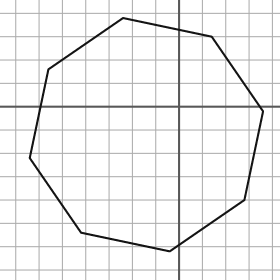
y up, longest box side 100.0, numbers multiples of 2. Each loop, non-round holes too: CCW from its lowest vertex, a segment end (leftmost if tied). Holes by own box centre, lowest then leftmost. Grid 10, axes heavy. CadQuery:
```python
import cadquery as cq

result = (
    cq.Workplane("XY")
    .moveTo(-4.0, -62.0)
    .lineTo(28.0, -40.0)
    .lineTo(36.0, -2.0)
    .lineTo(14.0, 30.0)
    .lineTo(-24.0, 38.0)
    .lineTo(-56.0, 16.0)
    .lineTo(-64.0, -22.0)
    .lineTo(-42.0, -54.0)
    .close()
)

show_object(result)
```